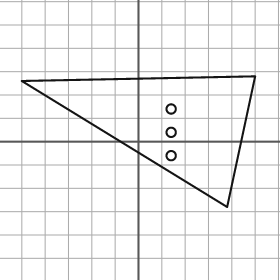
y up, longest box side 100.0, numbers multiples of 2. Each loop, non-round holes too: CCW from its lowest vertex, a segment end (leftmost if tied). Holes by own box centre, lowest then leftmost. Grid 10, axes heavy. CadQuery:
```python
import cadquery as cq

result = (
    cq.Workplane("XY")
    .moveTo(38.0, -28.0)
    .lineTo(50.0, 28.0)
    .lineTo(-50.0, 26.0)
    .close()
    .moveTo(14.0, -6.0)
    .circle(2.0)
    .moveTo(14.0, 4.0)
    .circle(2.0)
    .moveTo(14.0, 14.0)
    .circle(2.0)
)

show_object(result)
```